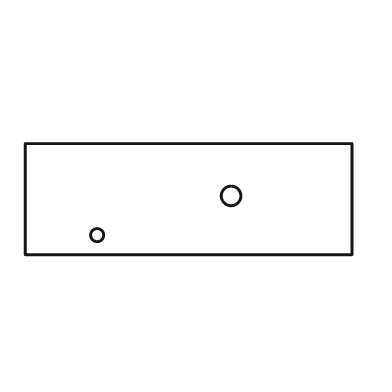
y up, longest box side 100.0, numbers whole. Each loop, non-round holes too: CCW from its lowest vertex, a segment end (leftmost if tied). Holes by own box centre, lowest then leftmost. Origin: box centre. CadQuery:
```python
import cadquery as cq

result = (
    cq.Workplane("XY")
    .moveTo(-50.0, -17.0)
    .lineTo(50.0, -17.0)
    .lineTo(50.0, 17.0)
    .lineTo(-50.0, 17.0)
    .close()
    .moveTo(-28.0, -11.0)
    .circle(2.0)
    .moveTo(13.0, 1.0)
    .circle(3.0)
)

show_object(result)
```